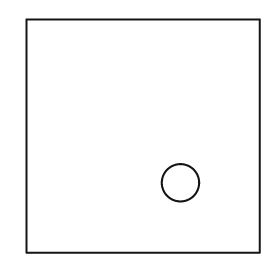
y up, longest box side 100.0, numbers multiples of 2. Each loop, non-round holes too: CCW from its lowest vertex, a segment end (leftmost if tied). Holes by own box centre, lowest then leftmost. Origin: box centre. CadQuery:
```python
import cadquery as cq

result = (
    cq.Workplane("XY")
    .moveTo(-50.0, -50.0)
    .lineTo(50.0, -50.0)
    .lineTo(50.0, 50.0)
    .lineTo(-50.0, 50.0)
    .close()
    .moveTo(16.0, -20.0)
    .circle(8.0)
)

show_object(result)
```